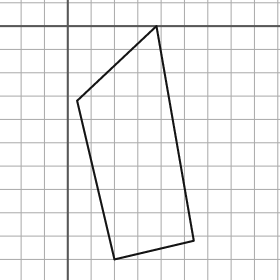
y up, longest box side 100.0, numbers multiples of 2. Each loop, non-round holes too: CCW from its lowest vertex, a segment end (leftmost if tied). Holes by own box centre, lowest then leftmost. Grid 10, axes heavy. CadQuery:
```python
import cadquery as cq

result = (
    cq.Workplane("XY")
    .moveTo(20.0, -100.0)
    .lineTo(54.0, -92.0)
    .lineTo(38.0, 0.0)
    .lineTo(4.0, -32.0)
    .close()
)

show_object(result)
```